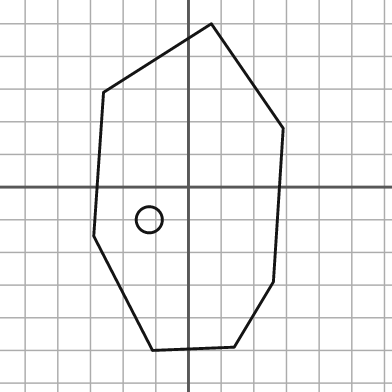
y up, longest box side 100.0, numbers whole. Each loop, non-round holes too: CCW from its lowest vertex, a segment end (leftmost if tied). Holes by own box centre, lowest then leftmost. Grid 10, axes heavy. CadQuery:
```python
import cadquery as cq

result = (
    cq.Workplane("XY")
    .moveTo(-11.0, -50.0)
    .lineTo(14.0, -49.0)
    .lineTo(26.0, -29.0)
    .lineTo(29.0, 18.0)
    .lineTo(7.0, 50.0)
    .lineTo(-26.0, 29.0)
    .lineTo(-29.0, -15.0)
    .close()
    .moveTo(-12.0, -10.0)
    .circle(4.0)
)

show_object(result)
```